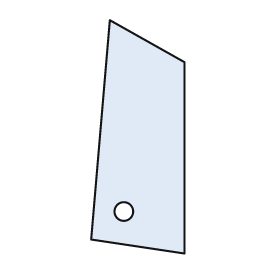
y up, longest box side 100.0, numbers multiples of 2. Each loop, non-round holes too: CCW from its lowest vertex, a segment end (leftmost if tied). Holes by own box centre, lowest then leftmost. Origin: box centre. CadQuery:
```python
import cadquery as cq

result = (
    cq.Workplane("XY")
    .moveTo(20.0, -50.0)
    .lineTo(20.0, 32.0)
    .lineTo(-12.0, 50.0)
    .lineTo(-20.0, -44.0)
    .close()
    .moveTo(-6.0, -32.0)
    .circle(4.0)
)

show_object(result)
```